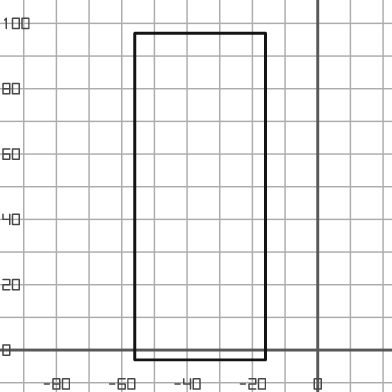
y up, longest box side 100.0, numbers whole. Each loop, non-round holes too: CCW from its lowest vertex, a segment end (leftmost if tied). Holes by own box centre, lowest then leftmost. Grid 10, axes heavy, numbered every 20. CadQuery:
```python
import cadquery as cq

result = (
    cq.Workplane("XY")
    .moveTo(-56.0, -3.0)
    .lineTo(-16.0, -3.0)
    .lineTo(-16.0, 97.0)
    .lineTo(-56.0, 97.0)
    .close()
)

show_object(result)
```